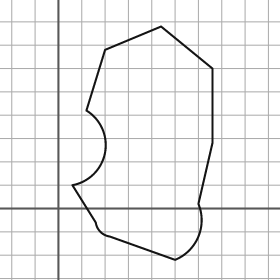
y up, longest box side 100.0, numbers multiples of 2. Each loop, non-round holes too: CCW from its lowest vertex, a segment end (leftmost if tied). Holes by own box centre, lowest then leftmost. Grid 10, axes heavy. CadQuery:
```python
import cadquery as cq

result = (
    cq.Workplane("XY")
    .moveTo(50.0, -22.0)
    .threePointArc((60.0, -12.0), (60.0, 2.0))
    .lineTo(66.0, 28.0)
    .lineTo(66.0, 60.0)
    .lineTo(44.0, 78.0)
    .lineTo(20.0, 68.0)
    .lineTo(12.0, 42.0)
    .threePointArc((20.0, 24.0), (6.0, 10.0))
    .lineTo(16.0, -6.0)
    .threePointArc((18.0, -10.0), (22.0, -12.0))
    .close()
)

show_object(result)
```